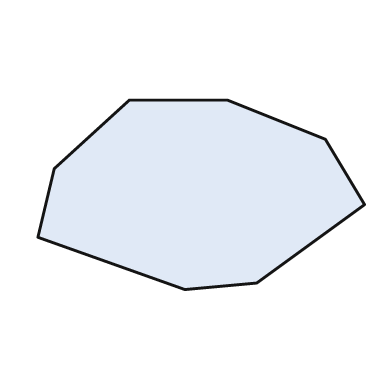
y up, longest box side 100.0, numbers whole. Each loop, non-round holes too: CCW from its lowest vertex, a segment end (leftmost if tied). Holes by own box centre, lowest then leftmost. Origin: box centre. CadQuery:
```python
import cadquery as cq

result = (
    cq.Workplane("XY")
    .moveTo(-5.0, -29.0)
    .lineTo(17.0, -27.0)
    .lineTo(50.0, -3.0)
    .lineTo(38.0, 17.0)
    .lineTo(8.0, 29.0)
    .lineTo(-22.0, 29.0)
    .lineTo(-45.0, 8.0)
    .lineTo(-50.0, -13.0)
    .close()
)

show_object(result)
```